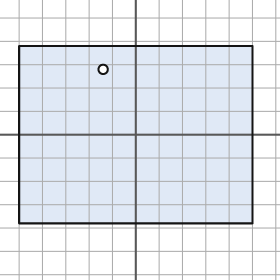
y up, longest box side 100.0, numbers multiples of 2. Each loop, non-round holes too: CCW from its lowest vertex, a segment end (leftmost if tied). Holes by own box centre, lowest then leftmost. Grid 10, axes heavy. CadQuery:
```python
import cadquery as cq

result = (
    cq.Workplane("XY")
    .moveTo(-50.0, -38.0)
    .lineTo(50.0, -38.0)
    .lineTo(50.0, 38.0)
    .lineTo(-50.0, 38.0)
    .close()
    .moveTo(-14.0, 28.0)
    .circle(2.0)
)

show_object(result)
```